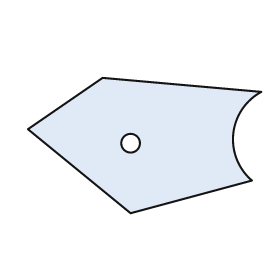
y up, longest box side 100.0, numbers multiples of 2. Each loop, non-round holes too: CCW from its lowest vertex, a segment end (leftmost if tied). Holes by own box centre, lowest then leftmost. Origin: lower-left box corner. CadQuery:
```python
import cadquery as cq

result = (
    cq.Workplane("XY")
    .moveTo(44.0, 0.0)
    .lineTo(96.0, 14.0)
    .threePointArc((88.0, 34.0), (100.0, 52.0))
    .lineTo(32.0, 58.0)
    .lineTo(0.0, 36.0)
    .close()
    .moveTo(44.0, 30.0)
    .circle(4.0)
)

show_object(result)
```